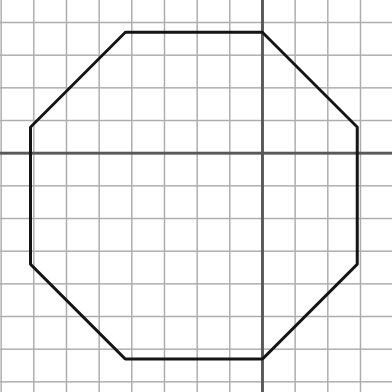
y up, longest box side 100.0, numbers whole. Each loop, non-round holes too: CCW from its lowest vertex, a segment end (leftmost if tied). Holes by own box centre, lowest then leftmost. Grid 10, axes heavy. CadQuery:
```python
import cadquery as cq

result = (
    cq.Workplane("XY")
    .moveTo(-42.0, -63.0)
    .lineTo(0.0, -63.0)
    .lineTo(29.0, -34.0)
    .lineTo(29.0, 8.0)
    .lineTo(0.0, 37.0)
    .lineTo(-42.0, 37.0)
    .lineTo(-71.0, 8.0)
    .lineTo(-71.0, -34.0)
    .close()
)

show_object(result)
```